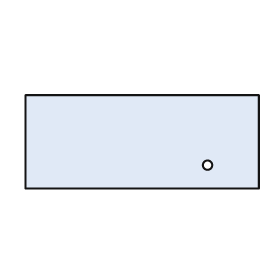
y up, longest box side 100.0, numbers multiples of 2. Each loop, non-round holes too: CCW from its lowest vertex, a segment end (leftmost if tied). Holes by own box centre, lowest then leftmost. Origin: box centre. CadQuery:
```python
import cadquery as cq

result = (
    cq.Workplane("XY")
    .moveTo(-50.0, -20.0)
    .lineTo(50.0, -20.0)
    .lineTo(50.0, 20.0)
    .lineTo(-50.0, 20.0)
    .close()
    .moveTo(28.0, -10.0)
    .circle(2.0)
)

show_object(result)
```